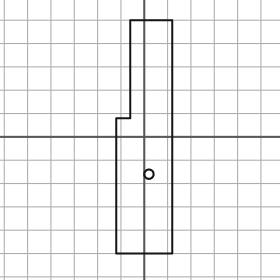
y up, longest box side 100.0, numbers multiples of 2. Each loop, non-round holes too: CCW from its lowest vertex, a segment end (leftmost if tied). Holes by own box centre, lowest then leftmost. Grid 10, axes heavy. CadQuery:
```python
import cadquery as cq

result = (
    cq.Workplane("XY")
    .moveTo(-12.0, -50.0)
    .lineTo(12.0, -50.0)
    .lineTo(12.0, 50.0)
    .lineTo(-6.0, 50.0)
    .lineTo(-6.0, 8.0)
    .lineTo(-12.0, 8.0)
    .close()
    .moveTo(2.0, -16.0)
    .circle(2.0)
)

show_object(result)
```